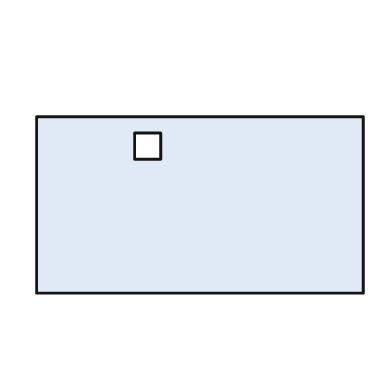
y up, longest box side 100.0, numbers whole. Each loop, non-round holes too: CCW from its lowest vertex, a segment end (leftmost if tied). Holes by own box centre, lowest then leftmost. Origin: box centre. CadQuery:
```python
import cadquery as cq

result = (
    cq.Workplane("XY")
    .moveTo(-50.0, -27.0)
    .lineTo(50.0, -27.0)
    .lineTo(50.0, 27.0)
    .lineTo(-50.0, 27.0)
    .close()
    .moveTo(-20.0, 14.0)
    .lineTo(-12.0, 14.0)
    .lineTo(-12.0, 22.0)
    .lineTo(-20.0, 22.0)
    .close()
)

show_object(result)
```